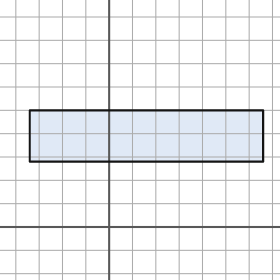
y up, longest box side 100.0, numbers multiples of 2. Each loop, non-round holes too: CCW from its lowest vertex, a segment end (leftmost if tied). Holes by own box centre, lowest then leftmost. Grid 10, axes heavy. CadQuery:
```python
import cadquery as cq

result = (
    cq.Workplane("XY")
    .moveTo(-34.0, 28.0)
    .lineTo(66.0, 28.0)
    .lineTo(66.0, 50.0)
    .lineTo(-34.0, 50.0)
    .close()
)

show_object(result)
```